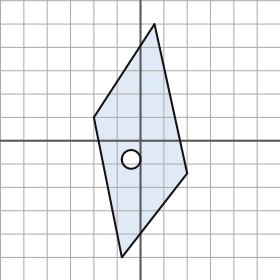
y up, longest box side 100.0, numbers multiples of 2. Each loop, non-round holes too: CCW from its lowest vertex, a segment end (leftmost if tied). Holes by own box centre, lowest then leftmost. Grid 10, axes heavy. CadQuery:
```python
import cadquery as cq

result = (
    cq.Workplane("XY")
    .moveTo(-8.0, -50.0)
    .lineTo(20.0, -14.0)
    .lineTo(6.0, 50.0)
    .lineTo(-20.0, 10.0)
    .close()
    .moveTo(-4.0, -8.0)
    .circle(4.0)
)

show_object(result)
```